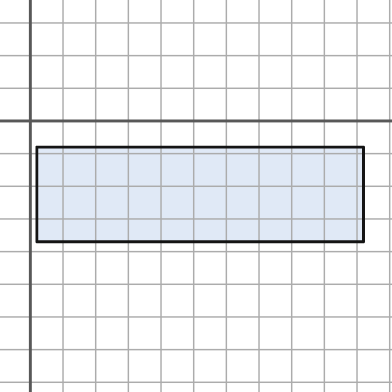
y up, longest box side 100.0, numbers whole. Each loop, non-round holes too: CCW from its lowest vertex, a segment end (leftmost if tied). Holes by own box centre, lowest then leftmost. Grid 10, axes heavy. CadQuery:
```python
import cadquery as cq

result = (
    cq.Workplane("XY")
    .moveTo(2.0, -37.0)
    .lineTo(102.0, -37.0)
    .lineTo(102.0, -8.0)
    .lineTo(2.0, -8.0)
    .close()
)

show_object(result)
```